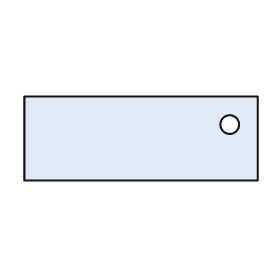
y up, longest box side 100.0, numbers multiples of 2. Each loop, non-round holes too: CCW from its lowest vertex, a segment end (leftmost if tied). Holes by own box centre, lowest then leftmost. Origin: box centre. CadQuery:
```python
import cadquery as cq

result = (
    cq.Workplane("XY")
    .moveTo(-50.0, -18.0)
    .lineTo(50.0, -18.0)
    .lineTo(50.0, 18.0)
    .lineTo(-50.0, 18.0)
    .close()
    .moveTo(38.0, 6.0)
    .circle(4.0)
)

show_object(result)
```